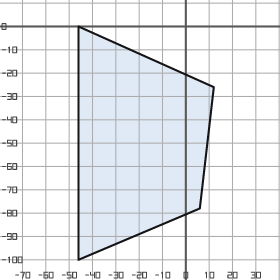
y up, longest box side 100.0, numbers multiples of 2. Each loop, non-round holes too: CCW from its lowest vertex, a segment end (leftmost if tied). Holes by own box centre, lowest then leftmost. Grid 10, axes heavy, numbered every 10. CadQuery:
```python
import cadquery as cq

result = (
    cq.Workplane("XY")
    .moveTo(-46.0, -100.0)
    .lineTo(6.0, -78.0)
    .lineTo(12.0, -26.0)
    .lineTo(-46.0, 0.0)
    .close()
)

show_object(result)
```